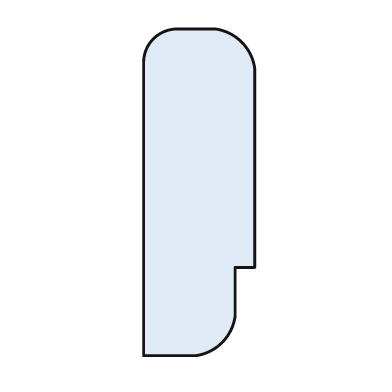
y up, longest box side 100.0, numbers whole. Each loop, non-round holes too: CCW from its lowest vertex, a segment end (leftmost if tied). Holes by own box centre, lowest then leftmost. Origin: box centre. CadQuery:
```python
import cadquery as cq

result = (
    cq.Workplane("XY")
    .moveTo(-17.0, -50.0)
    .lineTo(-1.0, -50.0)
    .threePointArc((7.0, -46.0), (11.0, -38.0))
    .lineTo(11.0, -23.0)
    .lineTo(17.0, -23.0)
    .lineTo(17.0, 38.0)
    .threePointArc((13.0, 46.0), (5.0, 50.0))
    .lineTo(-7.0, 50.0)
    .threePointArc((-14.0, 47.0), (-17.0, 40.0))
    .close()
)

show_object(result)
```